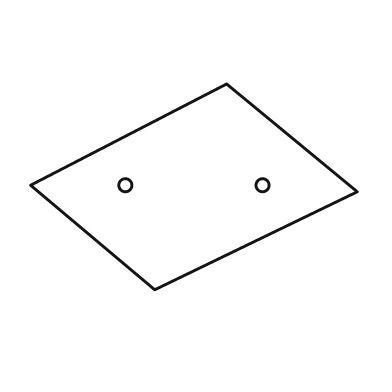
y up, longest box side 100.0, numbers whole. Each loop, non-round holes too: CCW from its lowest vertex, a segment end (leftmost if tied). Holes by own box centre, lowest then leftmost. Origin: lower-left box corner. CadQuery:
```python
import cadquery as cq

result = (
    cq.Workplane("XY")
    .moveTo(38.0, 0.0)
    .lineTo(100.0, 30.0)
    .lineTo(60.0, 63.0)
    .lineTo(0.0, 32.0)
    .close()
    .moveTo(29.0, 32.0)
    .circle(2.0)
    .moveTo(71.0, 32.0)
    .circle(2.0)
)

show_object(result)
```